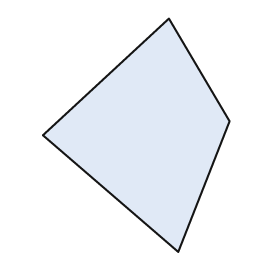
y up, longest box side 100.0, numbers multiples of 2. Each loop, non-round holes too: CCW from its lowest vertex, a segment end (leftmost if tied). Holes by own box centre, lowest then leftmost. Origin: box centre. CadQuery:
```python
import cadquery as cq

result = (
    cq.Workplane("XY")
    .moveTo(18.0, -50.0)
    .lineTo(40.0, 6.0)
    .lineTo(14.0, 50.0)
    .lineTo(-40.0, 0.0)
    .close()
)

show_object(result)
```